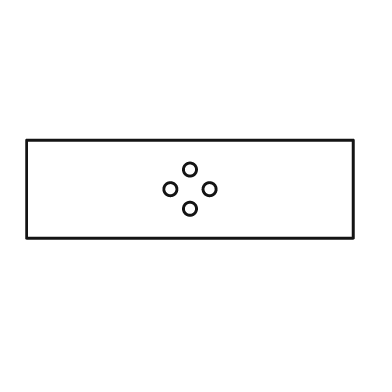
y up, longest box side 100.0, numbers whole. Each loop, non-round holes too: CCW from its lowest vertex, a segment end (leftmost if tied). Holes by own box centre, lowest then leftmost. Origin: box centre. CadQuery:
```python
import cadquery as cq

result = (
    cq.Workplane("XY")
    .moveTo(-50.0, -15.0)
    .lineTo(50.0, -15.0)
    .lineTo(50.0, 15.0)
    .lineTo(-50.0, 15.0)
    .close()
    .moveTo(0.0, -6.0)
    .circle(2.0)
    .moveTo(-6.0, 0.0)
    .circle(2.0)
    .moveTo(6.0, 0.0)
    .circle(2.0)
    .moveTo(0.0, 6.0)
    .circle(2.0)
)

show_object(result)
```